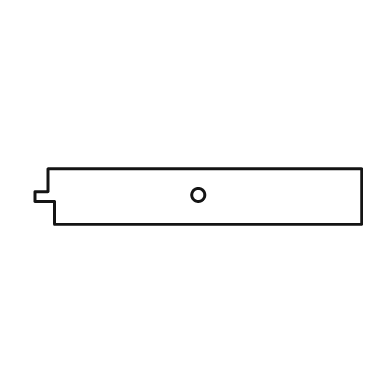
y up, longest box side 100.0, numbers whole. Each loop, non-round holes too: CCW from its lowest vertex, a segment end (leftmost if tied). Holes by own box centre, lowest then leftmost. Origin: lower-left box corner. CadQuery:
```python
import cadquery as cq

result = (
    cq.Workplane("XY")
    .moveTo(6.0, 0.0)
    .lineTo(100.0, 0.0)
    .lineTo(100.0, 17.0)
    .lineTo(4.0, 17.0)
    .lineTo(4.0, 10.0)
    .lineTo(0.0, 10.0)
    .lineTo(0.0, 7.0)
    .lineTo(6.0, 7.0)
    .close()
    .moveTo(50.0, 9.0)
    .circle(2.0)
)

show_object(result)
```